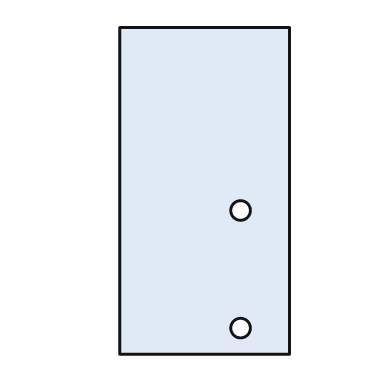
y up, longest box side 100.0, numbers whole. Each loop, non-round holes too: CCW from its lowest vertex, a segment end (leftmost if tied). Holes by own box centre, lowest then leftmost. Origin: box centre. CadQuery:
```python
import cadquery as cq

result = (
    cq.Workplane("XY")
    .moveTo(-26.0, -50.0)
    .lineTo(26.0, -50.0)
    .lineTo(26.0, 50.0)
    .lineTo(-26.0, 50.0)
    .close()
    .moveTo(11.0, -42.0)
    .circle(3.0)
    .moveTo(11.0, -6.0)
    .circle(3.0)
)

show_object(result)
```